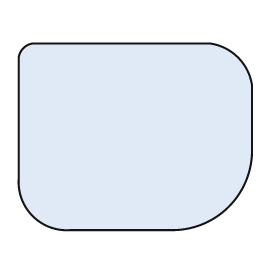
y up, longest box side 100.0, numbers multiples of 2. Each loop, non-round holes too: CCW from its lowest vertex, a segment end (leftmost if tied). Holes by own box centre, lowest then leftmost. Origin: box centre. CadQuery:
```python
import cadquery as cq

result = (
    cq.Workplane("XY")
    .moveTo(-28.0, -40.0)
    .lineTo(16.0, -40.0)
    .threePointArc((40.0, -30.0), (50.0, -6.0))
    .lineTo(50.0, 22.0)
    .threePointArc((44.0, 34.0), (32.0, 40.0))
    .lineTo(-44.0, 40.0)
    .threePointArc((-48.0, 38.0), (-50.0, 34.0))
    .lineTo(-50.0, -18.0)
    .threePointArc((-44.0, -34.0), (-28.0, -40.0))
    .close()
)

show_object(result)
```